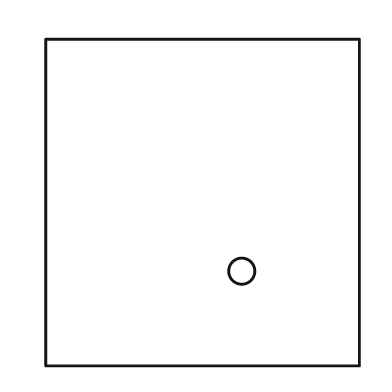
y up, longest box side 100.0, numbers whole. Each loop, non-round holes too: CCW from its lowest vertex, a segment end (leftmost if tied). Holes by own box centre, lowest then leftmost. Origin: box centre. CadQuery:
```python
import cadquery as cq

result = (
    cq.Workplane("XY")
    .moveTo(-48.0, -50.0)
    .lineTo(48.0, -50.0)
    .lineTo(48.0, 50.0)
    .lineTo(-48.0, 50.0)
    .close()
    .moveTo(12.0, -21.0)
    .circle(4.0)
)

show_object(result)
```